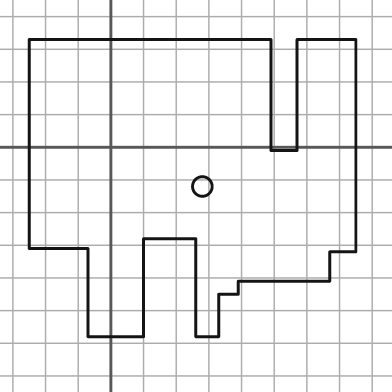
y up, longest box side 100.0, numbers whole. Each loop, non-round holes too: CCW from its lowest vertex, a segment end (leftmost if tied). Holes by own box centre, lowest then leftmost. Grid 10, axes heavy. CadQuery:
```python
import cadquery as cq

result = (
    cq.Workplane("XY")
    .moveTo(-7.0, -58.0)
    .lineTo(10.0, -58.0)
    .lineTo(10.0, -28.0)
    .lineTo(26.0, -28.0)
    .lineTo(26.0, -58.0)
    .lineTo(33.0, -58.0)
    .lineTo(33.0, -45.0)
    .lineTo(39.0, -45.0)
    .lineTo(39.0, -41.0)
    .lineTo(67.0, -41.0)
    .lineTo(67.0, -32.0)
    .lineTo(75.0, -32.0)
    .lineTo(75.0, 33.0)
    .lineTo(57.0, 33.0)
    .lineTo(57.0, -1.0)
    .lineTo(49.0, -1.0)
    .lineTo(49.0, 33.0)
    .lineTo(-25.0, 33.0)
    .lineTo(-25.0, -31.0)
    .lineTo(-7.0, -31.0)
    .close()
    .moveTo(28.0, -12.0)
    .circle(3.0)
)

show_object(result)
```